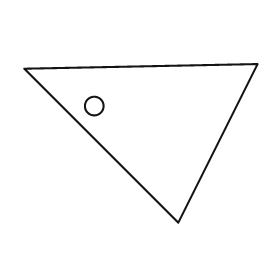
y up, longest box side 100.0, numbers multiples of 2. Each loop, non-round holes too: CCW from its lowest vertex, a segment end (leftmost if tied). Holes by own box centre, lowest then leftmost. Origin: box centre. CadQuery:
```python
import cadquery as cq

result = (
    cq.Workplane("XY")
    .moveTo(16.0, -34.0)
    .lineTo(50.0, 34.0)
    .lineTo(-50.0, 32.0)
    .close()
    .moveTo(-20.0, 16.0)
    .circle(4.0)
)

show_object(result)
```